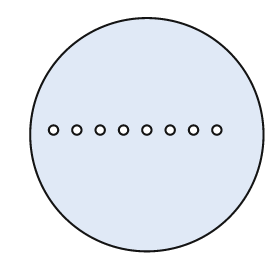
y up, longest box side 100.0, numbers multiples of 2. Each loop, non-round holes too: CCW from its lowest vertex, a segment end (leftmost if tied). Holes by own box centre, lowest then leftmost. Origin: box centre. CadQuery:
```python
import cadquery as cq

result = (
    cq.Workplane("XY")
    .moveTo(0.0, 0.0)
    .circle(50.0)
    .moveTo(-40.0, 2.0)
    .circle(2.0)
    .moveTo(-30.0, 2.0)
    .circle(2.0)
    .moveTo(-20.0, 2.0)
    .circle(2.0)
    .moveTo(-10.0, 2.0)
    .circle(2.0)
    .moveTo(0.0, 2.0)
    .circle(2.0)
    .moveTo(10.0, 2.0)
    .circle(2.0)
    .moveTo(20.0, 2.0)
    .circle(2.0)
    .moveTo(30.0, 2.0)
    .circle(2.0)
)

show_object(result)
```